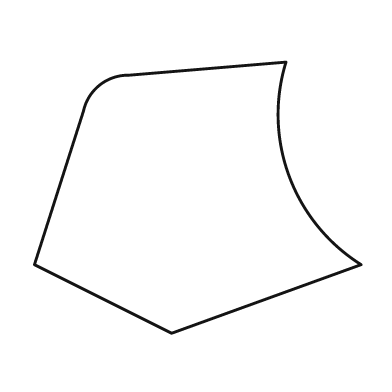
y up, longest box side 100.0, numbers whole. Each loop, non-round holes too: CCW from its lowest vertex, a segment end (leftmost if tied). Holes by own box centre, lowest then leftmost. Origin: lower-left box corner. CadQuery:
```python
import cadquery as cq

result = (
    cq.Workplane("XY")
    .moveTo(42.0, 0.0)
    .lineTo(100.0, 21.0)
    .threePointArc((78.0, 48.0), (77.0, 83.0))
    .lineTo(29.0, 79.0)
    .threePointArc((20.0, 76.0), (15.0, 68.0))
    .lineTo(0.0, 21.0)
    .close()
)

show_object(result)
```